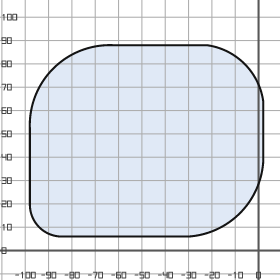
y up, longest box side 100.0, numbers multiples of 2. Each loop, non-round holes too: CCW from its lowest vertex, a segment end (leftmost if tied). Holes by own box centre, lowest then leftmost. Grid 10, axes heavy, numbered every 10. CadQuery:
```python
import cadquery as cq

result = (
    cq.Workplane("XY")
    .moveTo(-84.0, 6.0)
    .lineTo(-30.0, 6.0)
    .threePointArc((-8.0, 16.0), (2.0, 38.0))
    .lineTo(2.0, 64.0)
    .threePointArc((-6.0, 80.0), (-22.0, 88.0))
    .lineTo(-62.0, 88.0)
    .threePointArc((-88.0, 78.0), (-98.0, 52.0))
    .lineTo(-98.0, 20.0)
    .threePointArc((-94.0, 10.0), (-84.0, 6.0))
    .close()
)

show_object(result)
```